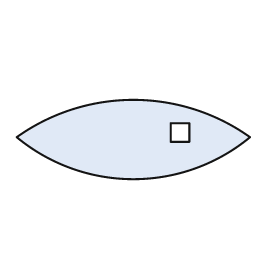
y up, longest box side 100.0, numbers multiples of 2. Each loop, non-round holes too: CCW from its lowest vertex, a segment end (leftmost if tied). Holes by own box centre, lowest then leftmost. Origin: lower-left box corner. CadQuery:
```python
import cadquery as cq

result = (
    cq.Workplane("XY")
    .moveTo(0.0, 18.0)
    .threePointArc((50.0, 0.0), (100.0, 18.0))
    .threePointArc((50.0, 34.0), (0.0, 18.0))
    .close()
    .moveTo(66.0, 16.0)
    .lineTo(74.0, 16.0)
    .lineTo(74.0, 24.0)
    .lineTo(66.0, 24.0)
    .close()
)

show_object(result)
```